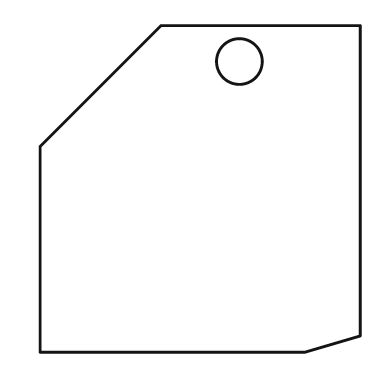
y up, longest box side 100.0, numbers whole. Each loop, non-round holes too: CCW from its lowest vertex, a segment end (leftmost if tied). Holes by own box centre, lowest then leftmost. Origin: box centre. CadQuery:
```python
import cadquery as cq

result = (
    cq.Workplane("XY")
    .moveTo(-49.0, -50.0)
    .lineTo(32.0, -50.0)
    .lineTo(49.0, -45.0)
    .lineTo(49.0, 50.0)
    .lineTo(-12.0, 50.0)
    .lineTo(-49.0, 13.0)
    .close()
    .moveTo(12.0, 39.0)
    .circle(7.0)
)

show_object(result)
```